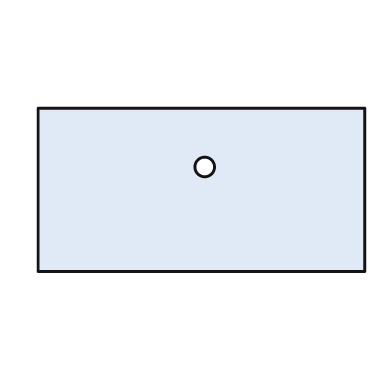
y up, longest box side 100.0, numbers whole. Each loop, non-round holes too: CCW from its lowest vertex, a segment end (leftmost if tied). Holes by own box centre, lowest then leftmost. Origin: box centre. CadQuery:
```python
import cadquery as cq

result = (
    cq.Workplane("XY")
    .moveTo(-50.0, -25.0)
    .lineTo(50.0, -25.0)
    .lineTo(50.0, 25.0)
    .lineTo(-50.0, 25.0)
    .close()
    .moveTo(1.0, 7.0)
    .circle(3.0)
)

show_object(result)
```